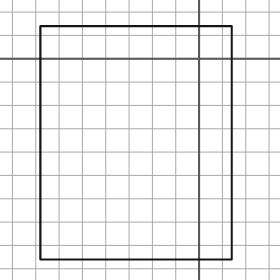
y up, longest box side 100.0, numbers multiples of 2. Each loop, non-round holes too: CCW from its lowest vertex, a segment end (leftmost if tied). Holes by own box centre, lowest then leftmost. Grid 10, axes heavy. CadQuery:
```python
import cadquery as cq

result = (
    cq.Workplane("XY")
    .moveTo(-68.0, -86.0)
    .lineTo(14.0, -86.0)
    .lineTo(14.0, 14.0)
    .lineTo(-68.0, 14.0)
    .close()
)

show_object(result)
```